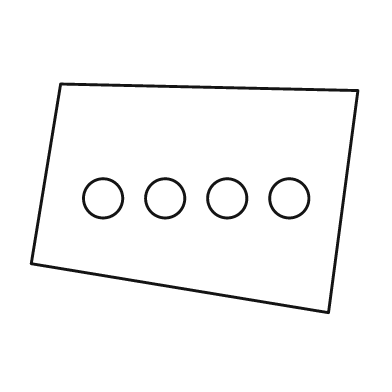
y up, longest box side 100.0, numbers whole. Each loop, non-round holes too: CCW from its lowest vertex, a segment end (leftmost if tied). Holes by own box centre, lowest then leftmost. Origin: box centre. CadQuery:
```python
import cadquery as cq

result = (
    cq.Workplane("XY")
    .moveTo(41.0, -35.0)
    .lineTo(50.0, 33.0)
    .lineTo(-41.0, 35.0)
    .lineTo(-50.0, -20.0)
    .close()
    .moveTo(-28.0, 0.0)
    .circle(6.0)
    .moveTo(-9.0, 0.0)
    .circle(6.0)
    .moveTo(10.0, 0.0)
    .circle(6.0)
    .moveTo(29.0, 0.0)
    .circle(6.0)
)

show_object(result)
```